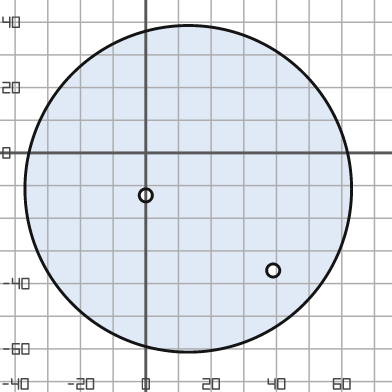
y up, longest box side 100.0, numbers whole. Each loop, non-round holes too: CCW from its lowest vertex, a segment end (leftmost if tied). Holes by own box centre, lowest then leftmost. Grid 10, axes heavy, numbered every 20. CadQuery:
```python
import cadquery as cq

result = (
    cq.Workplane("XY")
    .moveTo(13.0, -11.0)
    .circle(50.0)
    .moveTo(39.0, -36.0)
    .circle(2.0)
    .moveTo(0.0, -13.0)
    .circle(2.0)
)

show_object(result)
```